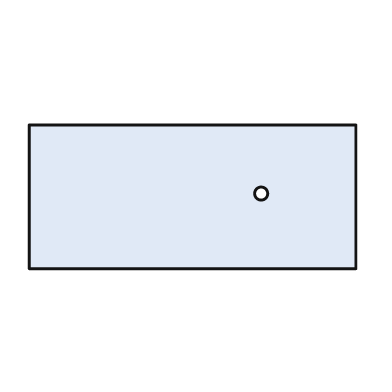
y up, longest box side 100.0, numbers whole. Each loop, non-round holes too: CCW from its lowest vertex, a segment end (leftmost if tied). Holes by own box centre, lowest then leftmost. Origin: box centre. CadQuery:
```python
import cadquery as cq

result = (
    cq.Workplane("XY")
    .moveTo(-50.0, -22.0)
    .lineTo(50.0, -22.0)
    .lineTo(50.0, 22.0)
    .lineTo(-50.0, 22.0)
    .close()
    .moveTo(21.0, 1.0)
    .circle(2.0)
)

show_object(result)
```